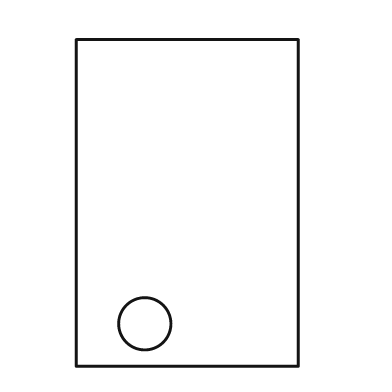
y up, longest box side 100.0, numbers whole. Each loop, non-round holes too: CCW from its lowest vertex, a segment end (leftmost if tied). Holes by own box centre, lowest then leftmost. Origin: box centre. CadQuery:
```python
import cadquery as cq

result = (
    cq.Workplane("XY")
    .moveTo(-34.0, -50.0)
    .lineTo(34.0, -50.0)
    .lineTo(34.0, 50.0)
    .lineTo(-34.0, 50.0)
    .close()
    .moveTo(-13.0, -37.0)
    .circle(8.0)
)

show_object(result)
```